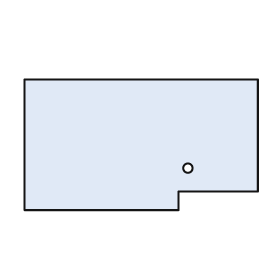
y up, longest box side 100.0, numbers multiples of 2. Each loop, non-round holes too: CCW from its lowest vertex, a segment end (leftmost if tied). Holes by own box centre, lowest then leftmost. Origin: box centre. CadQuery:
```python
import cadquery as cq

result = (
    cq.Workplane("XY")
    .moveTo(-50.0, -28.0)
    .lineTo(16.0, -28.0)
    .lineTo(16.0, -20.0)
    .lineTo(50.0, -20.0)
    .lineTo(50.0, 28.0)
    .lineTo(-50.0, 28.0)
    .close()
    .moveTo(20.0, -10.0)
    .circle(2.0)
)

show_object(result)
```